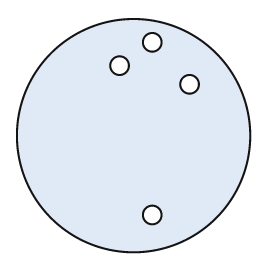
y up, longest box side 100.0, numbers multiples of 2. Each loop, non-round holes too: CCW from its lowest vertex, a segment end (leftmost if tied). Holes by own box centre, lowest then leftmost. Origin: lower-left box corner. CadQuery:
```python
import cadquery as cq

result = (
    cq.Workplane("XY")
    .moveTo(50.0, 50.0)
    .circle(50.0)
    .moveTo(58.0, 16.0)
    .circle(4.0)
    .moveTo(74.0, 72.0)
    .circle(4.0)
    .moveTo(44.0, 80.0)
    .circle(4.0)
    .moveTo(58.0, 90.0)
    .circle(4.0)
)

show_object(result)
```